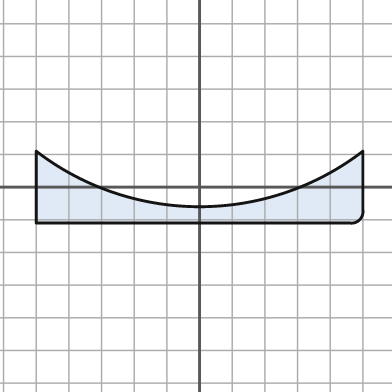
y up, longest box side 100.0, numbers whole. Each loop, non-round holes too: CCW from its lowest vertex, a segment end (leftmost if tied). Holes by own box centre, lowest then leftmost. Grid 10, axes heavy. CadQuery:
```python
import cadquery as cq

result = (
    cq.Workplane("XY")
    .moveTo(-50.0, -11.0)
    .lineTo(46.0, -11.0)
    .threePointArc((49.0, -10.0), (50.0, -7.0))
    .lineTo(50.0, 11.0)
    .threePointArc((0.0, -6.0), (-50.0, 11.0))
    .close()
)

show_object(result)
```